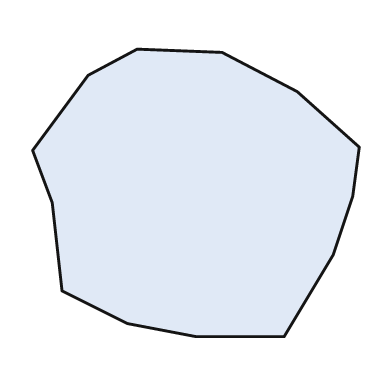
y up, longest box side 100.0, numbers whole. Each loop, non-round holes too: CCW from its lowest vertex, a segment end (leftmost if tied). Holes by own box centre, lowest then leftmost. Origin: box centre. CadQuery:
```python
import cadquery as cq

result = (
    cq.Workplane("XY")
    .moveTo(0.0, -44.0)
    .lineTo(27.0, -44.0)
    .lineTo(42.0, -19.0)
    .lineTo(48.0, -1.0)
    .lineTo(50.0, 14.0)
    .lineTo(31.0, 31.0)
    .lineTo(8.0, 43.0)
    .lineTo(-18.0, 44.0)
    .lineTo(-33.0, 36.0)
    .lineTo(-50.0, 13.0)
    .lineTo(-44.0, -3.0)
    .lineTo(-41.0, -30.0)
    .lineTo(-21.0, -40.0)
    .close()
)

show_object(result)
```